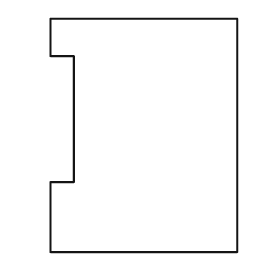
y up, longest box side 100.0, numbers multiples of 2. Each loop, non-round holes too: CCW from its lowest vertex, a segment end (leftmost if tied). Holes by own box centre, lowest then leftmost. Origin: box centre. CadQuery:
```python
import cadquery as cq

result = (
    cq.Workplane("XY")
    .moveTo(-40.0, -50.0)
    .lineTo(40.0, -50.0)
    .lineTo(40.0, 50.0)
    .lineTo(-40.0, 50.0)
    .lineTo(-40.0, 34.0)
    .lineTo(-30.0, 34.0)
    .lineTo(-30.0, -20.0)
    .lineTo(-40.0, -20.0)
    .close()
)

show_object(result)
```